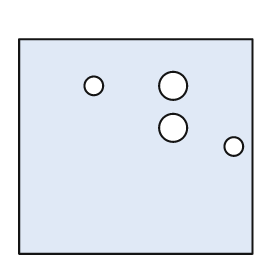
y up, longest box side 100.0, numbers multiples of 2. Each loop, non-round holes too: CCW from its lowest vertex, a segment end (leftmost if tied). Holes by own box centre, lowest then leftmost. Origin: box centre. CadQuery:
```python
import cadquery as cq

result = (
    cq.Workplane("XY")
    .moveTo(-50.0, -46.0)
    .lineTo(50.0, -46.0)
    .lineTo(50.0, 46.0)
    .lineTo(-50.0, 46.0)
    .close()
    .moveTo(42.0, 0.0)
    .circle(4.0)
    .moveTo(16.0, 8.0)
    .circle(6.0)
    .moveTo(-18.0, 26.0)
    .circle(4.0)
    .moveTo(16.0, 26.0)
    .circle(6.0)
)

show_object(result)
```